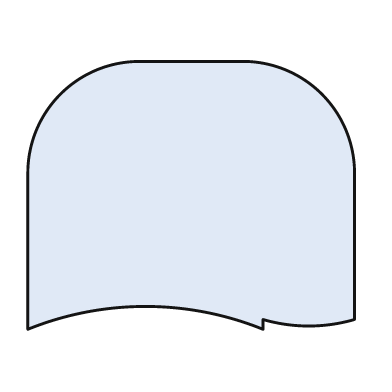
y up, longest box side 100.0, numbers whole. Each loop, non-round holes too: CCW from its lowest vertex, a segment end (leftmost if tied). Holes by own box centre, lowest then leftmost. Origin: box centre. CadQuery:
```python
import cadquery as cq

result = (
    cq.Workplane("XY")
    .moveTo(-50.0, -41.0)
    .threePointArc((-14.0, -34.0), (22.0, -41.0))
    .lineTo(22.0, -38.0)
    .threePointArc((36.0, -40.0), (50.0, -38.0))
    .lineTo(50.0, 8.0)
    .threePointArc((40.0, 31.0), (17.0, 41.0))
    .lineTo(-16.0, 41.0)
    .threePointArc((-40.0, 31.0), (-50.0, 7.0))
    .close()
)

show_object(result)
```